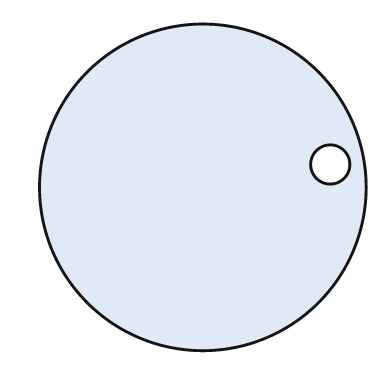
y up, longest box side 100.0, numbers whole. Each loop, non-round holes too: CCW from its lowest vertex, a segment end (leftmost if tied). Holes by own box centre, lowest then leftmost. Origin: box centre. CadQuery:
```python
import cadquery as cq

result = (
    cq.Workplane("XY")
    .moveTo(0.0, 0.0)
    .circle(50.0)
    .moveTo(39.0, 7.0)
    .circle(6.0)
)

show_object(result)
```